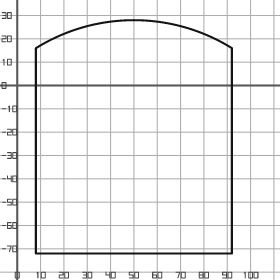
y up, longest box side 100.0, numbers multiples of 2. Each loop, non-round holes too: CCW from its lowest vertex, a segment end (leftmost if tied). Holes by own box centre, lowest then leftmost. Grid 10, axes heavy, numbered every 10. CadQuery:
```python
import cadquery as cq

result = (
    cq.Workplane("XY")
    .moveTo(8.0, -72.0)
    .lineTo(92.0, -72.0)
    .lineTo(92.0, 16.0)
    .threePointArc((50.0, 28.0), (8.0, 16.0))
    .close()
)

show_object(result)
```